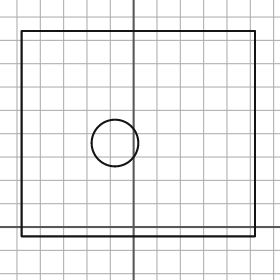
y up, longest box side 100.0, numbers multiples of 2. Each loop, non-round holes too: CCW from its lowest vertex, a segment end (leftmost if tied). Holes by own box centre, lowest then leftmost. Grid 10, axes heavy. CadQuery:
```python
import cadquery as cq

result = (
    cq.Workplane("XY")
    .moveTo(-48.0, -4.0)
    .lineTo(52.0, -4.0)
    .lineTo(52.0, 84.0)
    .lineTo(-48.0, 84.0)
    .close()
    .moveTo(-8.0, 36.0)
    .circle(10.0)
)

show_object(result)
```